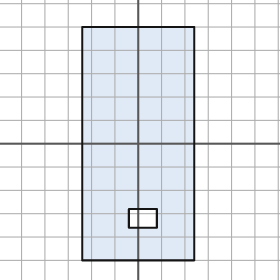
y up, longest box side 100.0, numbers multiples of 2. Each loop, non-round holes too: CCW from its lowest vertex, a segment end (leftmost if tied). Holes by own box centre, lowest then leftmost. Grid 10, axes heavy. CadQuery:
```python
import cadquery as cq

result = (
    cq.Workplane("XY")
    .moveTo(-24.0, -50.0)
    .lineTo(24.0, -50.0)
    .lineTo(24.0, 50.0)
    .lineTo(-24.0, 50.0)
    .close()
    .moveTo(-4.0, -36.0)
    .lineTo(8.0, -36.0)
    .lineTo(8.0, -28.0)
    .lineTo(-4.0, -28.0)
    .close()
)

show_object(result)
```